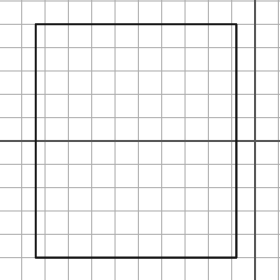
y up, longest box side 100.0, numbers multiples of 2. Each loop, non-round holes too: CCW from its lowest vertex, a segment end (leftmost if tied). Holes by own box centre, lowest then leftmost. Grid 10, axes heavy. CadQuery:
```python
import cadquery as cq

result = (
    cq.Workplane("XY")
    .moveTo(-94.0, -50.0)
    .lineTo(-8.0, -50.0)
    .lineTo(-8.0, 50.0)
    .lineTo(-94.0, 50.0)
    .close()
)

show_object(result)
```